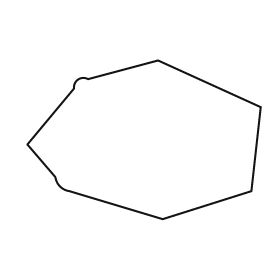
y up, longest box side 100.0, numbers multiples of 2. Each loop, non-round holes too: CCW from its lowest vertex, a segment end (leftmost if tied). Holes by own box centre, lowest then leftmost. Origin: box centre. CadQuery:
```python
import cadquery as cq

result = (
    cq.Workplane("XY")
    .moveTo(8.0, -34.0)
    .lineTo(46.0, -22.0)
    .lineTo(50.0, 14.0)
    .lineTo(6.0, 34.0)
    .lineTo(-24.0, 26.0)
    .threePointArc((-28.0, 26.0), (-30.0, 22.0))
    .lineTo(-50.0, -2.0)
    .lineTo(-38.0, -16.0)
    .threePointArc((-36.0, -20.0), (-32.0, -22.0))
    .close()
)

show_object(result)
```